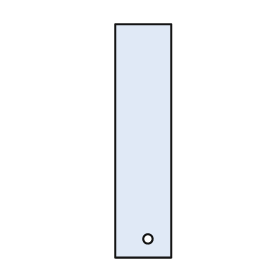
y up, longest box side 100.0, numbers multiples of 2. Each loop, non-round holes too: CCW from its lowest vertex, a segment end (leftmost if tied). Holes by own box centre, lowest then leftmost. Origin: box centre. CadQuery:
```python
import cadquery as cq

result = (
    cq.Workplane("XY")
    .moveTo(-12.0, -50.0)
    .lineTo(12.0, -50.0)
    .lineTo(12.0, 50.0)
    .lineTo(-12.0, 50.0)
    .close()
    .moveTo(2.0, -42.0)
    .circle(2.0)
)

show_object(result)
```